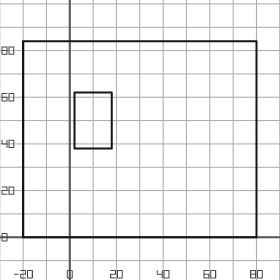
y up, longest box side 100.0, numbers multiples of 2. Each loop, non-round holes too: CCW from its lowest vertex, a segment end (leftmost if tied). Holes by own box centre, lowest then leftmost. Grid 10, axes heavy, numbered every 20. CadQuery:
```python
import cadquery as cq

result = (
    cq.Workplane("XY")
    .moveTo(-20.0, 0.0)
    .lineTo(80.0, 0.0)
    .lineTo(80.0, 84.0)
    .lineTo(-20.0, 84.0)
    .close()
    .moveTo(2.0, 38.0)
    .lineTo(18.0, 38.0)
    .lineTo(18.0, 62.0)
    .lineTo(2.0, 62.0)
    .close()
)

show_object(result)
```